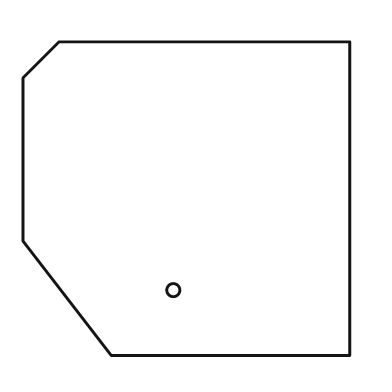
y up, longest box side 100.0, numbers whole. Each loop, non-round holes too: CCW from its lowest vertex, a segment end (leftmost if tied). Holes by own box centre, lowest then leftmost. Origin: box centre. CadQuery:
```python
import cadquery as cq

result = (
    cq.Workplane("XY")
    .moveTo(-23.0, -48.0)
    .lineTo(50.0, -48.0)
    .lineTo(50.0, 48.0)
    .lineTo(-39.0, 48.0)
    .lineTo(-50.0, 37.0)
    .lineTo(-50.0, -13.0)
    .close()
    .moveTo(-4.0, -28.0)
    .circle(2.0)
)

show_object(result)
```